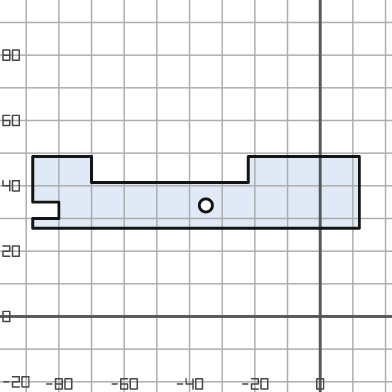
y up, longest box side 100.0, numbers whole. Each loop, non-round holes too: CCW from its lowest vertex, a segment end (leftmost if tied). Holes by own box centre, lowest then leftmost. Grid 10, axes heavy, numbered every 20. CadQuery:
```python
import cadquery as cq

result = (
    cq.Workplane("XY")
    .moveTo(-88.0, 27.0)
    .lineTo(12.0, 27.0)
    .lineTo(12.0, 49.0)
    .lineTo(-22.0, 49.0)
    .lineTo(-22.0, 41.0)
    .lineTo(-70.0, 41.0)
    .lineTo(-70.0, 49.0)
    .lineTo(-88.0, 49.0)
    .lineTo(-88.0, 35.0)
    .lineTo(-80.0, 35.0)
    .lineTo(-80.0, 30.0)
    .lineTo(-88.0, 30.0)
    .close()
    .moveTo(-35.0, 34.0)
    .circle(2.0)
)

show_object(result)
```